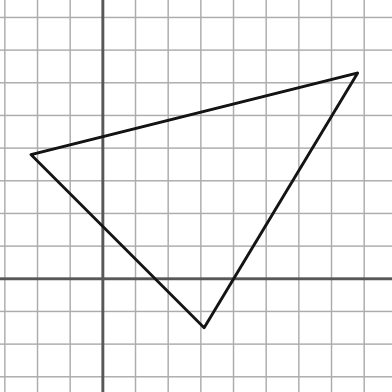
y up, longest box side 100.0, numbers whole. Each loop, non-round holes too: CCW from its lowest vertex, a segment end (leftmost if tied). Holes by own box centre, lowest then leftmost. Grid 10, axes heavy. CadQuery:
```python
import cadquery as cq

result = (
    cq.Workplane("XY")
    .moveTo(31.0, -15.0)
    .lineTo(78.0, 63.0)
    .lineTo(-22.0, 38.0)
    .close()
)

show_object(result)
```